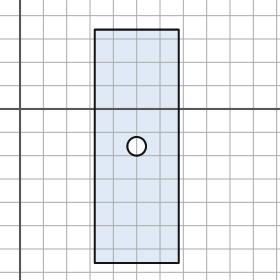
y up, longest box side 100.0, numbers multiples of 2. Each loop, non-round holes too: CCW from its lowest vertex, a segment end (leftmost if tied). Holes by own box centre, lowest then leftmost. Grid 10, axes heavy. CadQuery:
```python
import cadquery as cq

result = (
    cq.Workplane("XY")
    .moveTo(32.0, -66.0)
    .lineTo(68.0, -66.0)
    .lineTo(68.0, 34.0)
    .lineTo(32.0, 34.0)
    .close()
    .moveTo(50.0, -16.0)
    .circle(4.0)
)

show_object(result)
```